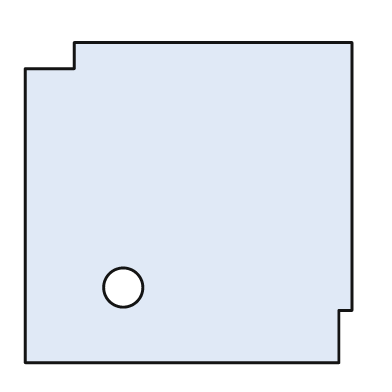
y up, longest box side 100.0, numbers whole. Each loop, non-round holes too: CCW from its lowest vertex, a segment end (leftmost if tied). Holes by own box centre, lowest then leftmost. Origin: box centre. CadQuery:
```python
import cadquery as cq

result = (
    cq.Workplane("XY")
    .moveTo(-50.0, -49.0)
    .lineTo(46.0, -49.0)
    .lineTo(46.0, -33.0)
    .lineTo(50.0, -33.0)
    .lineTo(50.0, 49.0)
    .lineTo(-35.0, 49.0)
    .lineTo(-35.0, 41.0)
    .lineTo(-50.0, 41.0)
    .close()
    .moveTo(-20.0, -26.0)
    .circle(6.0)
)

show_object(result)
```